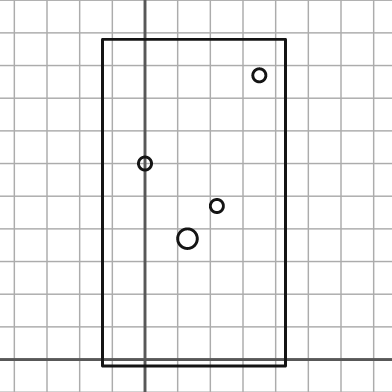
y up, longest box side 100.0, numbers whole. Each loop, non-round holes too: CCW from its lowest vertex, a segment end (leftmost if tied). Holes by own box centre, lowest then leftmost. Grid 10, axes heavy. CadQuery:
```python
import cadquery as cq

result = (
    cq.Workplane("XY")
    .moveTo(-13.0, -2.0)
    .lineTo(43.0, -2.0)
    .lineTo(43.0, 98.0)
    .lineTo(-13.0, 98.0)
    .close()
    .moveTo(13.0, 37.0)
    .circle(3.0)
    .moveTo(22.0, 47.0)
    .circle(2.0)
    .moveTo(0.0, 60.0)
    .circle(2.0)
    .moveTo(35.0, 87.0)
    .circle(2.0)
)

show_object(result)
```